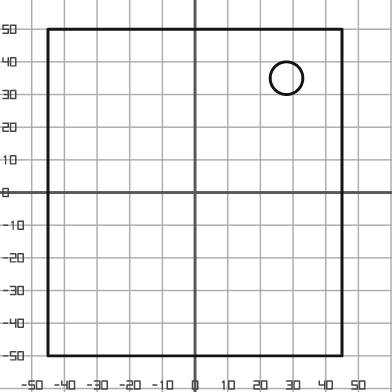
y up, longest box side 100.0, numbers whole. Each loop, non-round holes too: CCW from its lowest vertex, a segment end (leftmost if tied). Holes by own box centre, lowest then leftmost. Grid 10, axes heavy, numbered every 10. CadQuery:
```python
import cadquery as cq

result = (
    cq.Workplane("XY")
    .moveTo(-45.0, -50.0)
    .lineTo(45.0, -50.0)
    .lineTo(45.0, 50.0)
    .lineTo(-45.0, 50.0)
    .close()
    .moveTo(28.0, 35.0)
    .circle(5.0)
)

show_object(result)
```